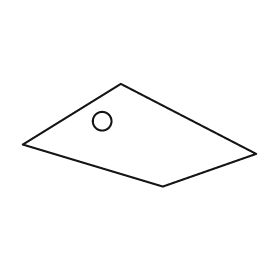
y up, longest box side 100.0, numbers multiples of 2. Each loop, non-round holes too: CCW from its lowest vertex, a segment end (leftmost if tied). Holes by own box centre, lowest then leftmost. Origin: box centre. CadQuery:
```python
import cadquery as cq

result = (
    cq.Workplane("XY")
    .moveTo(10.0, -22.0)
    .lineTo(50.0, -8.0)
    .lineTo(-8.0, 22.0)
    .lineTo(-50.0, -4.0)
    .close()
    .moveTo(-16.0, 6.0)
    .circle(4.0)
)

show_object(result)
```